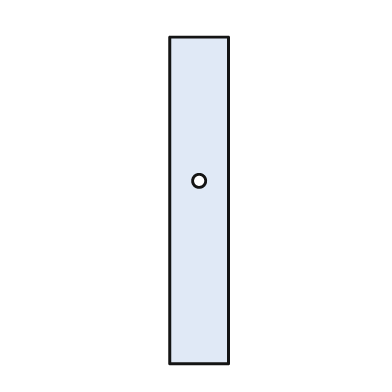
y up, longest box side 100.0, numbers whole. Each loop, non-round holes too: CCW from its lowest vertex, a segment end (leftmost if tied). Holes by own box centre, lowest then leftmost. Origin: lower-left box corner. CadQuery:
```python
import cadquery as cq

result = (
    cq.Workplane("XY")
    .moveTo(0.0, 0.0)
    .lineTo(18.0, 0.0)
    .lineTo(18.0, 100.0)
    .lineTo(0.0, 100.0)
    .close()
    .moveTo(9.0, 56.0)
    .circle(2.0)
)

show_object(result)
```